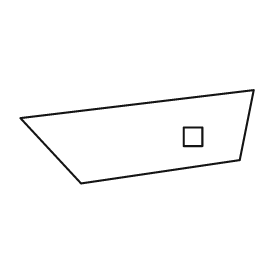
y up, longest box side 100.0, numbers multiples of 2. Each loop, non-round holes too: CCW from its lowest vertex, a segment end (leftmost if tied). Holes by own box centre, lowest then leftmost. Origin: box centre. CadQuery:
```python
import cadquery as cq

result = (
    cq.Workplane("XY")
    .moveTo(-24.0, -20.0)
    .lineTo(44.0, -10.0)
    .lineTo(50.0, 20.0)
    .lineTo(-50.0, 8.0)
    .close()
    .moveTo(20.0, -4.0)
    .lineTo(28.0, -4.0)
    .lineTo(28.0, 4.0)
    .lineTo(20.0, 4.0)
    .close()
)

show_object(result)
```